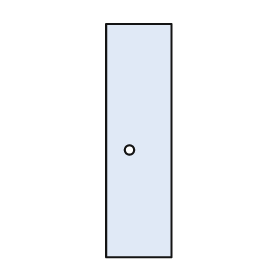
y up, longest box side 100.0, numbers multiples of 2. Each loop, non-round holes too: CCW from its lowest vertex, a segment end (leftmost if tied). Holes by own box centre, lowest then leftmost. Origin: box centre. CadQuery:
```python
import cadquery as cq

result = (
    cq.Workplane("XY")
    .moveTo(-14.0, -50.0)
    .lineTo(14.0, -50.0)
    .lineTo(14.0, 50.0)
    .lineTo(-14.0, 50.0)
    .close()
    .moveTo(-4.0, -4.0)
    .circle(2.0)
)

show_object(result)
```